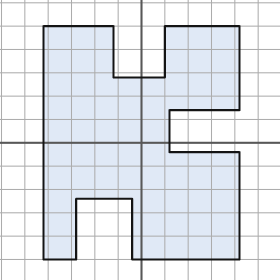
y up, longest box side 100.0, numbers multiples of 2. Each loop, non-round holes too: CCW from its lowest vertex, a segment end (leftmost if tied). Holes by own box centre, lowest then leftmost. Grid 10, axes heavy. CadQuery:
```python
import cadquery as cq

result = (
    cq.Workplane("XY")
    .moveTo(-42.0, -50.0)
    .lineTo(-28.0, -50.0)
    .lineTo(-28.0, -24.0)
    .lineTo(-4.0, -24.0)
    .lineTo(-4.0, -50.0)
    .lineTo(42.0, -50.0)
    .lineTo(42.0, -4.0)
    .lineTo(12.0, -4.0)
    .lineTo(12.0, 14.0)
    .lineTo(42.0, 14.0)
    .lineTo(42.0, 50.0)
    .lineTo(10.0, 50.0)
    .lineTo(10.0, 28.0)
    .lineTo(-12.0, 28.0)
    .lineTo(-12.0, 50.0)
    .lineTo(-42.0, 50.0)
    .close()
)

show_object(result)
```